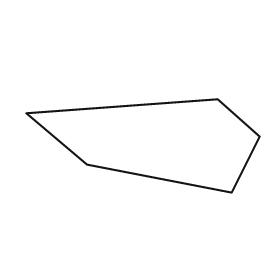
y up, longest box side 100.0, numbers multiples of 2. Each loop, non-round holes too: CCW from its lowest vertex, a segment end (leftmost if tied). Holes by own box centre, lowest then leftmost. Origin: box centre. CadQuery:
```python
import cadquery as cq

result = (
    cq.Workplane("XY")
    .moveTo(38.0, -20.0)
    .lineTo(50.0, 4.0)
    .lineTo(32.0, 20.0)
    .lineTo(-50.0, 14.0)
    .lineTo(-24.0, -8.0)
    .close()
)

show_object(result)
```